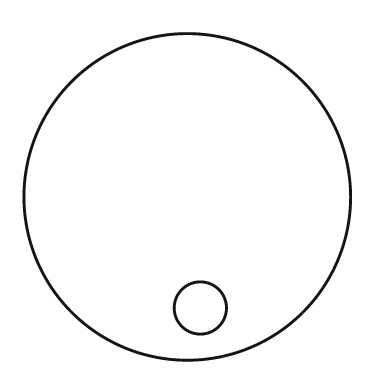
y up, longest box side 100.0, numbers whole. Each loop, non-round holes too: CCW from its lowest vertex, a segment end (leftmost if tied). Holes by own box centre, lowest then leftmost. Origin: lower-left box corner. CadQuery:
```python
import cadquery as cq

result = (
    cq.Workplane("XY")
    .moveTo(50.0, 50.0)
    .circle(50.0)
    .moveTo(54.0, 16.0)
    .circle(8.0)
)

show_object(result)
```